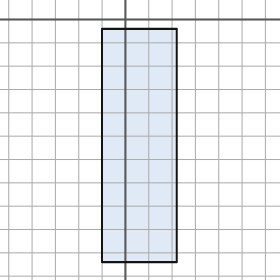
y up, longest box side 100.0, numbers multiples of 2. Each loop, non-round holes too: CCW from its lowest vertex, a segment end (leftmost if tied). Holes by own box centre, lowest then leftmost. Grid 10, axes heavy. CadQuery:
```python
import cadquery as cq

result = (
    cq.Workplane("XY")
    .moveTo(-10.0, -104.0)
    .lineTo(22.0, -104.0)
    .lineTo(22.0, -4.0)
    .lineTo(-10.0, -4.0)
    .close()
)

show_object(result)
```